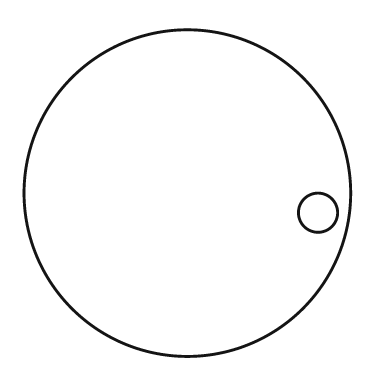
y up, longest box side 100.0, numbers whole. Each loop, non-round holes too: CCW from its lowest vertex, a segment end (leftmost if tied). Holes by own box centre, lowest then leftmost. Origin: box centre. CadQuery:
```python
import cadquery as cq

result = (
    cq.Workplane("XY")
    .moveTo(0.0, 0.0)
    .circle(50.0)
    .moveTo(40.0, -6.0)
    .circle(6.0)
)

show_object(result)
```